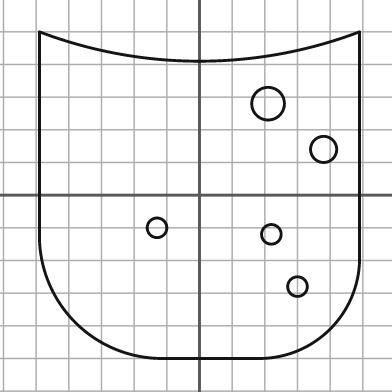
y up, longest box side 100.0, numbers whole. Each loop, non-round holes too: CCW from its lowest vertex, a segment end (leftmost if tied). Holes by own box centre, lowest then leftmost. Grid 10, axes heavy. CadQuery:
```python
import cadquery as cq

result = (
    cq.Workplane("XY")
    .moveTo(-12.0, -50.0)
    .lineTo(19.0, -50.0)
    .threePointArc((40.0, -41.0), (49.0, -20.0))
    .lineTo(49.0, 50.0)
    .threePointArc((0.0, 41.0), (-49.0, 50.0))
    .lineTo(-49.0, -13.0)
    .threePointArc((-38.0, -39.0), (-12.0, -50.0))
    .close()
    .moveTo(30.0, -28.0)
    .circle(3.0)
    .moveTo(22.0, -12.0)
    .circle(3.0)
    .moveTo(-13.0, -10.0)
    .circle(3.0)
    .moveTo(38.0, 14.0)
    .circle(4.0)
    .moveTo(21.0, 28.0)
    .circle(5.0)
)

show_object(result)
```